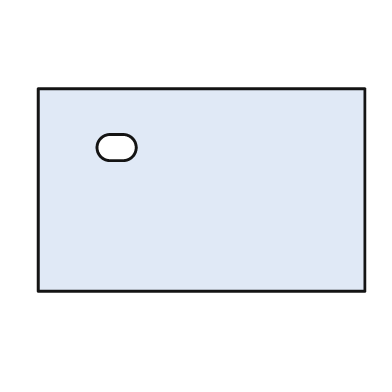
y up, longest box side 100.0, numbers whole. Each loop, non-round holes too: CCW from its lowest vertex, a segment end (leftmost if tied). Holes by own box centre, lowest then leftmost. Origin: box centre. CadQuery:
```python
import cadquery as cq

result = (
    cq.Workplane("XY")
    .moveTo(-50.0, -31.0)
    .lineTo(50.0, -31.0)
    .lineTo(50.0, 31.0)
    .lineTo(-50.0, 31.0)
    .close()
    .moveTo(-28.0, 9.0)
    .lineTo(-24.0, 9.0)
    .threePointArc((-20.0, 13.0), (-24.0, 17.0))
    .lineTo(-28.0, 17.0)
    .threePointArc((-32.0, 13.0), (-28.0, 9.0))
    .close()
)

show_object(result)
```